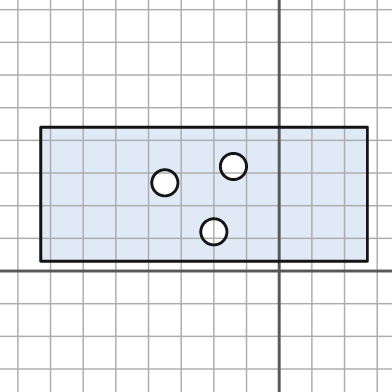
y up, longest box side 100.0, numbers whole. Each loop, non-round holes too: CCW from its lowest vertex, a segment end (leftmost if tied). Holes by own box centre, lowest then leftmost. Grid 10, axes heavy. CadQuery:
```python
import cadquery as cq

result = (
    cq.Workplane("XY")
    .moveTo(-73.0, 3.0)
    .lineTo(27.0, 3.0)
    .lineTo(27.0, 44.0)
    .lineTo(-73.0, 44.0)
    .close()
    .moveTo(-20.0, 12.0)
    .circle(4.0)
    .moveTo(-35.0, 27.0)
    .circle(4.0)
    .moveTo(-14.0, 32.0)
    .circle(4.0)
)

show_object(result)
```